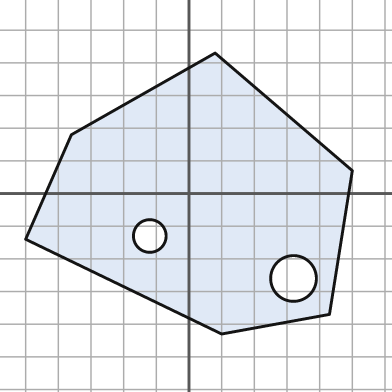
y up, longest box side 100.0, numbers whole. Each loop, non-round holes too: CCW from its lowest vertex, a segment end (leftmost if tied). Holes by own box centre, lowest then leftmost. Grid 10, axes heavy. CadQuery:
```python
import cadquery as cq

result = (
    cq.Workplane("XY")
    .moveTo(10.0, -43.0)
    .lineTo(43.0, -37.0)
    .lineTo(50.0, 7.0)
    .lineTo(8.0, 43.0)
    .lineTo(-36.0, 18.0)
    .lineTo(-50.0, -14.0)
    .close()
    .moveTo(32.0, -26.0)
    .circle(7.0)
    .moveTo(-12.0, -13.0)
    .circle(5.0)
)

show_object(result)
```